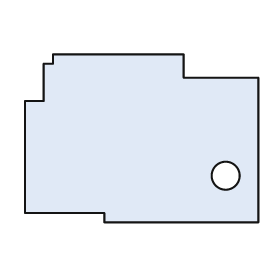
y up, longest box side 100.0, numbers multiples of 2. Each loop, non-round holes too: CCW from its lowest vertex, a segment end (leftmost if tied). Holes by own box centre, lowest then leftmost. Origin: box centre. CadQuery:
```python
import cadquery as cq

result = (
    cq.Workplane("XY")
    .moveTo(-16.0, -36.0)
    .lineTo(50.0, -36.0)
    .lineTo(50.0, 26.0)
    .lineTo(18.0, 26.0)
    .lineTo(18.0, 36.0)
    .lineTo(-38.0, 36.0)
    .lineTo(-38.0, 32.0)
    .lineTo(-42.0, 32.0)
    .lineTo(-42.0, 16.0)
    .lineTo(-50.0, 16.0)
    .lineTo(-50.0, -32.0)
    .lineTo(-16.0, -32.0)
    .close()
    .moveTo(36.0, -16.0)
    .circle(6.0)
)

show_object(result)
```